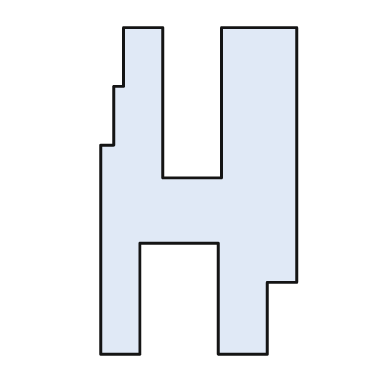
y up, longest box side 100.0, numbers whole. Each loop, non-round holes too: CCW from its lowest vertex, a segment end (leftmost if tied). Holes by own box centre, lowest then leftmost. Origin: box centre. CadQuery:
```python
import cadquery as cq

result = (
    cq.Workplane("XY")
    .moveTo(-30.0, -50.0)
    .lineTo(-18.0, -50.0)
    .lineTo(-18.0, -16.0)
    .lineTo(6.0, -16.0)
    .lineTo(6.0, -50.0)
    .lineTo(21.0, -50.0)
    .lineTo(21.0, -28.0)
    .lineTo(30.0, -28.0)
    .lineTo(30.0, 50.0)
    .lineTo(7.0, 50.0)
    .lineTo(7.0, 4.0)
    .lineTo(-11.0, 4.0)
    .lineTo(-11.0, 50.0)
    .lineTo(-23.0, 50.0)
    .lineTo(-23.0, 32.0)
    .lineTo(-26.0, 32.0)
    .lineTo(-26.0, 14.0)
    .lineTo(-30.0, 14.0)
    .close()
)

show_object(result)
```